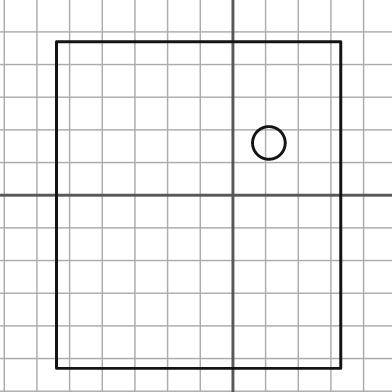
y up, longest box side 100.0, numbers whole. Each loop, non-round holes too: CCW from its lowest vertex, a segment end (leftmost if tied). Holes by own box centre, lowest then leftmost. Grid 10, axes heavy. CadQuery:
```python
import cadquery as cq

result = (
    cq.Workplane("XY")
    .moveTo(-54.0, -53.0)
    .lineTo(33.0, -53.0)
    .lineTo(33.0, 47.0)
    .lineTo(-54.0, 47.0)
    .close()
    .moveTo(11.0, 16.0)
    .circle(5.0)
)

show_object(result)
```